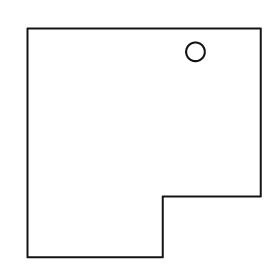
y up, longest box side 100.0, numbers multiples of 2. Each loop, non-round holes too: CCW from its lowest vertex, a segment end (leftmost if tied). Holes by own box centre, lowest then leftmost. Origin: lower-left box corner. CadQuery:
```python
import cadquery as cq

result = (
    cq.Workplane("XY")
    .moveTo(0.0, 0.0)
    .lineTo(58.0, 0.0)
    .lineTo(58.0, 26.0)
    .lineTo(100.0, 26.0)
    .lineTo(100.0, 98.0)
    .lineTo(0.0, 98.0)
    .close()
    .moveTo(72.0, 88.0)
    .circle(4.0)
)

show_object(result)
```